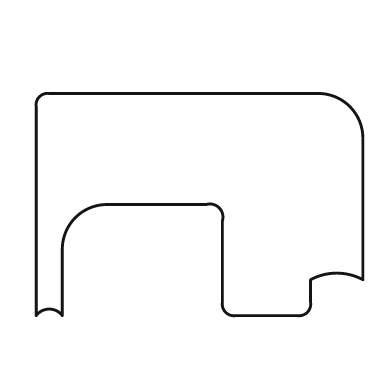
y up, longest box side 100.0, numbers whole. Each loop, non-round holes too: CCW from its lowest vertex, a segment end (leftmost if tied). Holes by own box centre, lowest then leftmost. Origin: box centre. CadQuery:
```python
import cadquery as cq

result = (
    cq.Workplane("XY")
    .moveTo(-50.0, -34.0)
    .threePointArc((-46.0, -32.0), (-42.0, -34.0))
    .lineTo(-42.0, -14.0)
    .threePointArc((-38.0, -4.0), (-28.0, 0.0))
    .lineTo(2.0, 0.0)
    .threePointArc((6.0, -1.0), (7.0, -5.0))
    .lineTo(7.0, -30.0)
    .threePointArc((8.0, -33.0), (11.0, -34.0))
    .lineTo(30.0, -34.0)
    .threePointArc((33.0, -33.0), (34.0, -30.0))
    .lineTo(34.0, -23.0)
    .threePointArc((42.0, -21.0), (50.0, -23.0))
    .lineTo(50.0, 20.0)
    .threePointArc((46.0, 30.0), (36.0, 34.0))
    .lineTo(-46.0, 34.0)
    .threePointArc((-49.0, 33.0), (-50.0, 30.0))
    .close()
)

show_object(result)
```